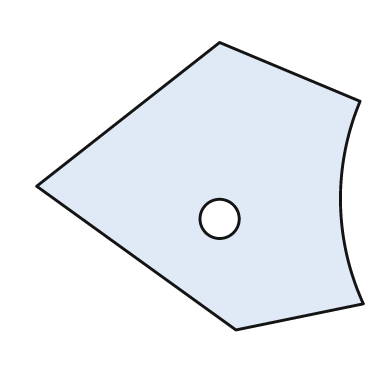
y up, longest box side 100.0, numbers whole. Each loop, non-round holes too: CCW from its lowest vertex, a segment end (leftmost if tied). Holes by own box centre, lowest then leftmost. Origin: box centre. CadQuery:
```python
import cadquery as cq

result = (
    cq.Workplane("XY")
    .moveTo(11.0, -44.0)
    .lineTo(50.0, -36.0)
    .threePointArc((43.0, -5.0), (49.0, 26.0))
    .lineTo(6.0, 44.0)
    .lineTo(-50.0, 0.0)
    .close()
    .moveTo(6.0, -10.0)
    .circle(6.0)
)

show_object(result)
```